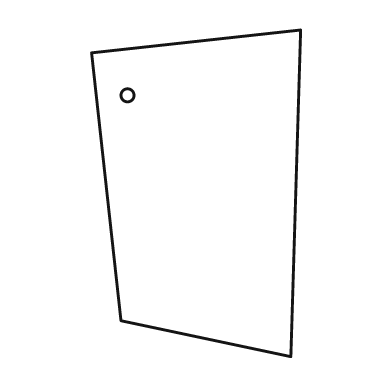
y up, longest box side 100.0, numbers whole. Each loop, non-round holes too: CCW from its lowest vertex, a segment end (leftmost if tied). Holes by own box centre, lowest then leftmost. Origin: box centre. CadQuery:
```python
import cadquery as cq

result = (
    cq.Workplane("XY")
    .moveTo(29.0, -50.0)
    .lineTo(32.0, 50.0)
    .lineTo(-32.0, 43.0)
    .lineTo(-23.0, -39.0)
    .close()
    .moveTo(-21.0, 30.0)
    .circle(2.0)
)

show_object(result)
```